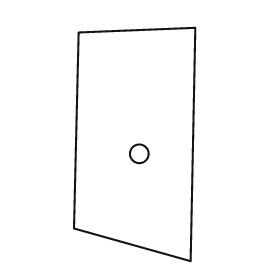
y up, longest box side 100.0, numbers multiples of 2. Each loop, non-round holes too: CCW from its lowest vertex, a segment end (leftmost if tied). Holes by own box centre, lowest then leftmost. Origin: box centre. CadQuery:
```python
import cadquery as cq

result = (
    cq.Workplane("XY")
    .moveTo(24.0, -50.0)
    .lineTo(26.0, 50.0)
    .lineTo(-24.0, 48.0)
    .lineTo(-26.0, -36.0)
    .close()
    .moveTo(2.0, -4.0)
    .circle(4.0)
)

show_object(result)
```